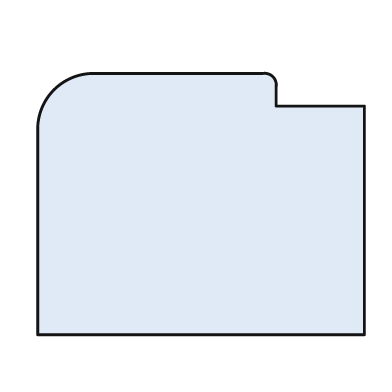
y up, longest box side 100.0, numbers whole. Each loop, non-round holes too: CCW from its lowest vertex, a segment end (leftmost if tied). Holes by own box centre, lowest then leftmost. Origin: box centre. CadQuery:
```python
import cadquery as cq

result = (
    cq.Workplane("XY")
    .moveTo(-50.0, -40.0)
    .lineTo(50.0, -40.0)
    .lineTo(50.0, 30.0)
    .lineTo(23.0, 30.0)
    .lineTo(23.0, 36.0)
    .threePointArc((22.0, 39.0), (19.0, 40.0))
    .lineTo(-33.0, 40.0)
    .threePointArc((-45.0, 35.0), (-50.0, 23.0))
    .close()
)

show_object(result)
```